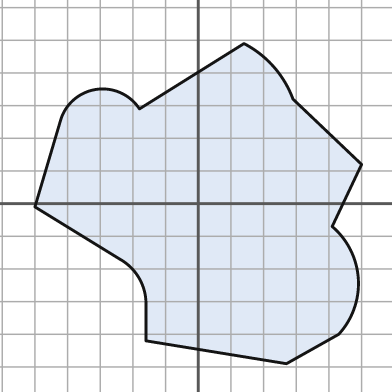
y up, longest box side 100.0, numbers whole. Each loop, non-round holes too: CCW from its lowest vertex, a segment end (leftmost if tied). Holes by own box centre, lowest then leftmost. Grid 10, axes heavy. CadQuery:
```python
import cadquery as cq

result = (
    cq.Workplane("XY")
    .moveTo(27.0, -49.0)
    .lineTo(43.0, -40.0)
    .threePointArc((49.0, -23.0), (41.0, -7.0))
    .lineTo(50.0, 12.0)
    .lineTo(29.0, 32.0)
    .threePointArc((23.0, 42.0), (14.0, 49.0))
    .lineTo(-18.0, 29.0)
    .threePointArc((-31.0, 35.0), (-42.0, 26.0))
    .lineTo(-50.0, -1.0)
    .lineTo(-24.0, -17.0)
    .threePointArc((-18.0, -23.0), (-16.0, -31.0))
    .lineTo(-16.0, -42.0)
    .close()
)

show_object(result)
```